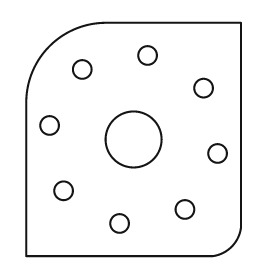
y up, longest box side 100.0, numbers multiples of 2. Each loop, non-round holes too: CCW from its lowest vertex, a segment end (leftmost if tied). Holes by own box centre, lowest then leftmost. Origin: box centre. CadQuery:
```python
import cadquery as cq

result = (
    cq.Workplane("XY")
    .moveTo(-46.0, -50.0)
    .lineTo(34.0, -50.0)
    .threePointArc((42.0, -46.0), (46.0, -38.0))
    .lineTo(46.0, 50.0)
    .lineTo(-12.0, 50.0)
    .threePointArc((-36.0, 40.0), (-46.0, 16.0))
    .close()
    .moveTo(-6.0, -36.0)
    .circle(4.0)
    .moveTo(22.0, -30.0)
    .circle(4.0)
    .moveTo(-30.0, -22.0)
    .circle(4.0)
    .moveTo(36.0, -6.0)
    .circle(4.0)
    .moveTo(0.0, 0.0)
    .circle(12.0)
    .moveTo(-36.0, 6.0)
    .circle(4.0)
    .moveTo(30.0, 22.0)
    .circle(4.0)
    .moveTo(-22.0, 30.0)
    .circle(4.0)
    .moveTo(6.0, 36.0)
    .circle(4.0)
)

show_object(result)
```